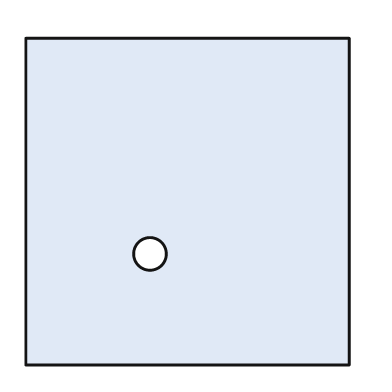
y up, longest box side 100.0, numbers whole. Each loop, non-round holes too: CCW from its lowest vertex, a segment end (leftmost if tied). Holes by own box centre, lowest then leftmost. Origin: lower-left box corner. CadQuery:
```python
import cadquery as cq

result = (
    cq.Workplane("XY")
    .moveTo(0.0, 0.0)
    .lineTo(99.0, 0.0)
    .lineTo(99.0, 100.0)
    .lineTo(0.0, 100.0)
    .close()
    .moveTo(38.0, 34.0)
    .circle(5.0)
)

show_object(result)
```